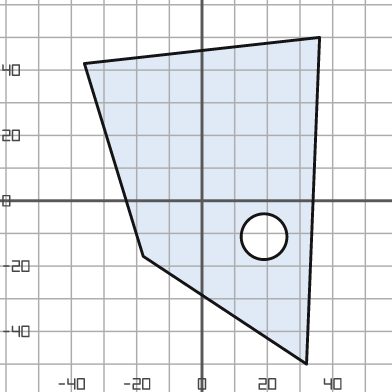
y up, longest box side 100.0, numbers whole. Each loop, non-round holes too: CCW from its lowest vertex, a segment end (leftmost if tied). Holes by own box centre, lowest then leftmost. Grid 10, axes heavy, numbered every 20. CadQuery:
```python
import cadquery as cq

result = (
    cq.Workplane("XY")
    .moveTo(32.0, -50.0)
    .lineTo(36.0, 50.0)
    .lineTo(-36.0, 42.0)
    .lineTo(-18.0, -17.0)
    .close()
    .moveTo(19.0, -11.0)
    .circle(7.0)
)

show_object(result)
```